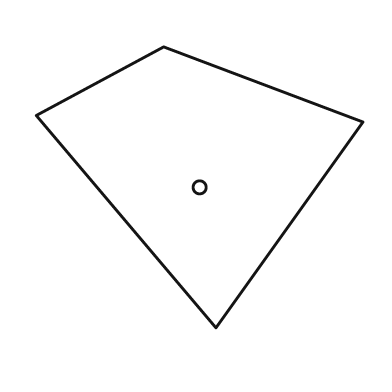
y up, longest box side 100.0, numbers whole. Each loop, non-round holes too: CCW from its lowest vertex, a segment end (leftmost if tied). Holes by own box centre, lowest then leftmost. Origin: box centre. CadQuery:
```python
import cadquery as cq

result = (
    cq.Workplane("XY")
    .moveTo(5.0, -43.0)
    .lineTo(50.0, 20.0)
    .lineTo(-11.0, 43.0)
    .lineTo(-50.0, 22.0)
    .close()
    .moveTo(0.0, 0.0)
    .circle(2.0)
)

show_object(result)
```